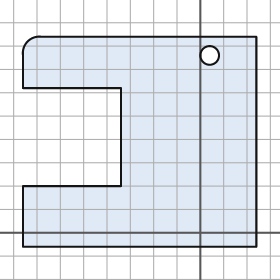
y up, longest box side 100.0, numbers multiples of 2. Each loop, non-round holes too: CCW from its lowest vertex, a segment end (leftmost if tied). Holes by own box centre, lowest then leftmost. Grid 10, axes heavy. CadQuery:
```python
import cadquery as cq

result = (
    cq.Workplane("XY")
    .moveTo(-76.0, -6.0)
    .lineTo(24.0, -6.0)
    .lineTo(24.0, 84.0)
    .lineTo(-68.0, 84.0)
    .threePointArc((-74.0, 82.0), (-76.0, 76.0))
    .lineTo(-76.0, 62.0)
    .lineTo(-34.0, 62.0)
    .lineTo(-34.0, 20.0)
    .lineTo(-76.0, 20.0)
    .close()
    .moveTo(4.0, 76.0)
    .circle(4.0)
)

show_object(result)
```